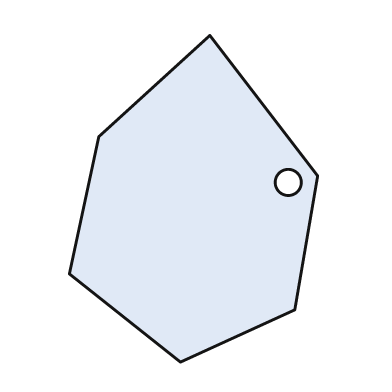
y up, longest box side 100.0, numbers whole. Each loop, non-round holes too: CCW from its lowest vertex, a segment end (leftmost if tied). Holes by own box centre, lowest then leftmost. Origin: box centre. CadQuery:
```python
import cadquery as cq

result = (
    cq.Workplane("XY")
    .moveTo(-4.0, -50.0)
    .lineTo(31.0, -34.0)
    .lineTo(38.0, 7.0)
    .lineTo(5.0, 50.0)
    .lineTo(-29.0, 19.0)
    .lineTo(-38.0, -23.0)
    .close()
    .moveTo(29.0, 5.0)
    .circle(4.0)
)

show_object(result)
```